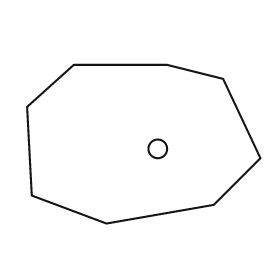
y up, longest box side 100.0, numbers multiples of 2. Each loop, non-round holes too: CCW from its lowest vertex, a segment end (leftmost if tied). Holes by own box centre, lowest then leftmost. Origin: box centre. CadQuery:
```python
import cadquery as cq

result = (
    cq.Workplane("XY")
    .moveTo(-16.0, -34.0)
    .lineTo(30.0, -26.0)
    .lineTo(50.0, -6.0)
    .lineTo(34.0, 28.0)
    .lineTo(10.0, 34.0)
    .lineTo(-30.0, 34.0)
    .lineTo(-50.0, 16.0)
    .lineTo(-48.0, -22.0)
    .close()
    .moveTo(6.0, -2.0)
    .circle(4.0)
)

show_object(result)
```